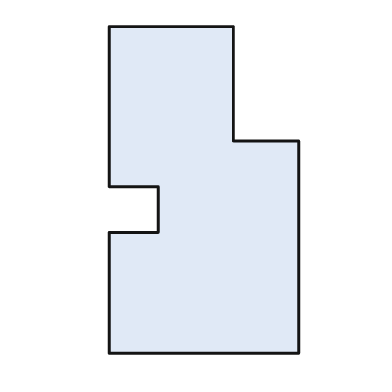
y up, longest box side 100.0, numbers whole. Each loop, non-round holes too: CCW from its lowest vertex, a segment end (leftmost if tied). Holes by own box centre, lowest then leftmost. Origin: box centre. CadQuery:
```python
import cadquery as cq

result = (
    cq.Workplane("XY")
    .moveTo(-29.0, -50.0)
    .lineTo(29.0, -50.0)
    .lineTo(29.0, 15.0)
    .lineTo(9.0, 15.0)
    .lineTo(9.0, 50.0)
    .lineTo(-29.0, 50.0)
    .lineTo(-29.0, 1.0)
    .lineTo(-14.0, 1.0)
    .lineTo(-14.0, -13.0)
    .lineTo(-29.0, -13.0)
    .close()
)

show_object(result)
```